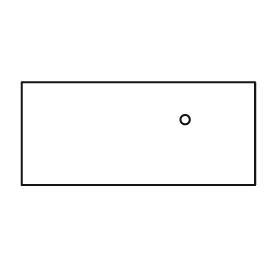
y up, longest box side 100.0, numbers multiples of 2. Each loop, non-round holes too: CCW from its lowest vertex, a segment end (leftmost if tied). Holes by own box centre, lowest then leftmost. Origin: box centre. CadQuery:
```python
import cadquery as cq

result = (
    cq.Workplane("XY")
    .moveTo(-50.0, -22.0)
    .lineTo(50.0, -22.0)
    .lineTo(50.0, 22.0)
    .lineTo(-50.0, 22.0)
    .close()
    .moveTo(20.0, 6.0)
    .circle(2.0)
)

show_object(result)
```